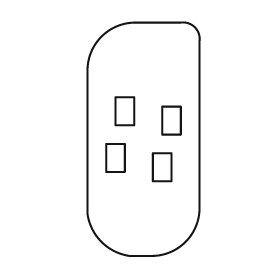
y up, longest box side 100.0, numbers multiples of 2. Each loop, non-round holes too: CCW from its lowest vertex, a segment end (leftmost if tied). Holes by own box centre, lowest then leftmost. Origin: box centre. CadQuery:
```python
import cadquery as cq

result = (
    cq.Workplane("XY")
    .moveTo(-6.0, -50.0)
    .lineTo(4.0, -50.0)
    .threePointArc((18.0, -44.0), (24.0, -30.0))
    .lineTo(24.0, 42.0)
    .threePointArc((22.0, 48.0), (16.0, 50.0))
    .lineTo(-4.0, 50.0)
    .threePointArc((-18.0, 44.0), (-24.0, 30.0))
    .lineTo(-24.0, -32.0)
    .threePointArc((-18.0, -44.0), (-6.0, -50.0))
    .close()
    .moveTo(4.0, -18.0)
    .lineTo(12.0, -18.0)
    .lineTo(12.0, -6.0)
    .lineTo(4.0, -6.0)
    .close()
    .moveTo(-16.0, -14.0)
    .lineTo(-8.0, -14.0)
    .lineTo(-8.0, -2.0)
    .lineTo(-16.0, -2.0)
    .close()
    .moveTo(8.0, 2.0)
    .lineTo(16.0, 2.0)
    .lineTo(16.0, 14.0)
    .lineTo(8.0, 14.0)
    .close()
    .moveTo(-12.0, 6.0)
    .lineTo(-4.0, 6.0)
    .lineTo(-4.0, 18.0)
    .lineTo(-12.0, 18.0)
    .close()
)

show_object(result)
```